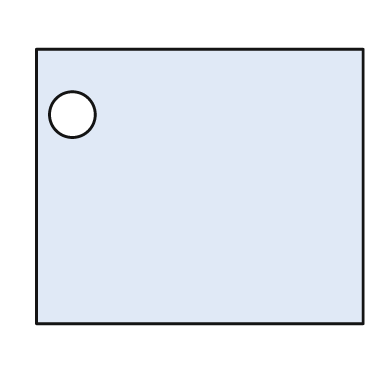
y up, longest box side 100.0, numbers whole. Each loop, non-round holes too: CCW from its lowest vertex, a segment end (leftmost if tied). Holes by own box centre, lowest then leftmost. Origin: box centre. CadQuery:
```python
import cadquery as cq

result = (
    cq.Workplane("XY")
    .moveTo(-50.0, -42.0)
    .lineTo(50.0, -42.0)
    .lineTo(50.0, 42.0)
    .lineTo(-50.0, 42.0)
    .close()
    .moveTo(-39.0, 22.0)
    .circle(7.0)
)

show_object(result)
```